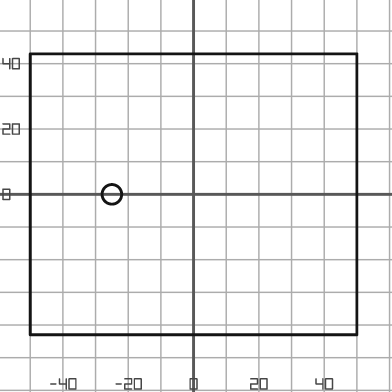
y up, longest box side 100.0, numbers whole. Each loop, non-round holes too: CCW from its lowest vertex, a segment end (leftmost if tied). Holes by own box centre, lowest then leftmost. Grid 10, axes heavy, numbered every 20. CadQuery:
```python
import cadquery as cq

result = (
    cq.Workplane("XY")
    .moveTo(-50.0, -43.0)
    .lineTo(50.0, -43.0)
    .lineTo(50.0, 43.0)
    .lineTo(-50.0, 43.0)
    .close()
    .moveTo(-25.0, 0.0)
    .circle(3.0)
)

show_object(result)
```